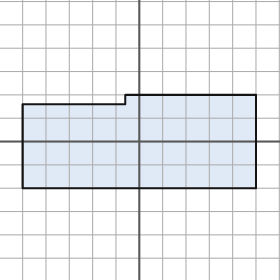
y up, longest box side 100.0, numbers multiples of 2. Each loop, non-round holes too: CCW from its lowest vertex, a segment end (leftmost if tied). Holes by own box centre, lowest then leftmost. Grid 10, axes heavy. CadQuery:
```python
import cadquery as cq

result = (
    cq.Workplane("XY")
    .moveTo(-50.0, -20.0)
    .lineTo(50.0, -20.0)
    .lineTo(50.0, 20.0)
    .lineTo(-6.0, 20.0)
    .lineTo(-6.0, 16.0)
    .lineTo(-50.0, 16.0)
    .close()
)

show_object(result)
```